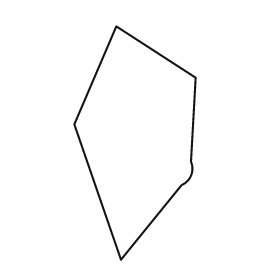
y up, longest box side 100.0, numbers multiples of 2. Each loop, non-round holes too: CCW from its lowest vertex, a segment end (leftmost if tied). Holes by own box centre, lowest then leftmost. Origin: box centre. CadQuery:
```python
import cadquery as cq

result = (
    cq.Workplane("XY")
    .moveTo(-6.0, -50.0)
    .lineTo(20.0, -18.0)
    .threePointArc((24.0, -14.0), (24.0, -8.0))
    .lineTo(26.0, 28.0)
    .lineTo(-8.0, 50.0)
    .lineTo(-26.0, 8.0)
    .close()
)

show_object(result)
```